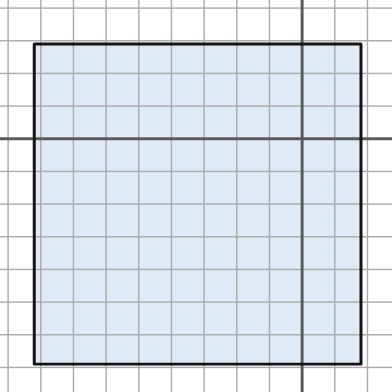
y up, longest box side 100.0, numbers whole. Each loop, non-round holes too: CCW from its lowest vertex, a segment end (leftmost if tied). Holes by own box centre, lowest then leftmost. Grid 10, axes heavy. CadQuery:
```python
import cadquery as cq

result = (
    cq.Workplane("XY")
    .moveTo(-82.0, -69.0)
    .lineTo(18.0, -69.0)
    .lineTo(18.0, 29.0)
    .lineTo(-82.0, 29.0)
    .close()
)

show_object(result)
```